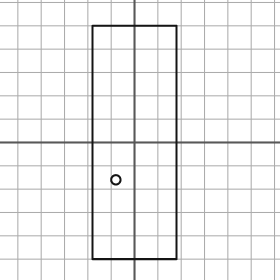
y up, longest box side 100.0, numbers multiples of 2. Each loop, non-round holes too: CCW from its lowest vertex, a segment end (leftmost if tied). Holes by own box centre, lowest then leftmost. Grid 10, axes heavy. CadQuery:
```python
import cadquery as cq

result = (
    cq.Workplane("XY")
    .moveTo(-18.0, -50.0)
    .lineTo(18.0, -50.0)
    .lineTo(18.0, 50.0)
    .lineTo(-18.0, 50.0)
    .close()
    .moveTo(-8.0, -16.0)
    .circle(2.0)
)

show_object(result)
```